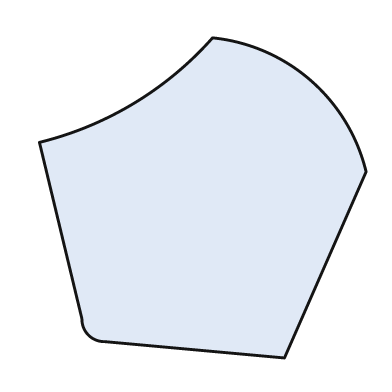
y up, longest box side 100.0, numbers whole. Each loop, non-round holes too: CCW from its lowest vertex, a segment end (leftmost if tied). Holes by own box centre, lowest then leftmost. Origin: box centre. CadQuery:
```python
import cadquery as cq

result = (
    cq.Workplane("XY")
    .moveTo(25.0, -49.0)
    .lineTo(50.0, 8.0)
    .threePointArc((33.0, 36.0), (3.0, 49.0))
    .threePointArc((-21.0, 29.0), (-50.0, 17.0))
    .lineTo(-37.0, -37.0)
    .threePointArc((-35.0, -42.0), (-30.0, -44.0))
    .close()
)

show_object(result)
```